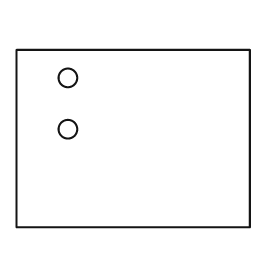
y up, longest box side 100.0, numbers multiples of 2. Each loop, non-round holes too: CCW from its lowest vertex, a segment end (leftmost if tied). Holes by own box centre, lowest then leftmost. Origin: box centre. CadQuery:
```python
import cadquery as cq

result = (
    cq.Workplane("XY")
    .moveTo(-50.0, -38.0)
    .lineTo(50.0, -38.0)
    .lineTo(50.0, 38.0)
    .lineTo(-50.0, 38.0)
    .close()
    .moveTo(-28.0, 4.0)
    .circle(4.0)
    .moveTo(-28.0, 26.0)
    .circle(4.0)
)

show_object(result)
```